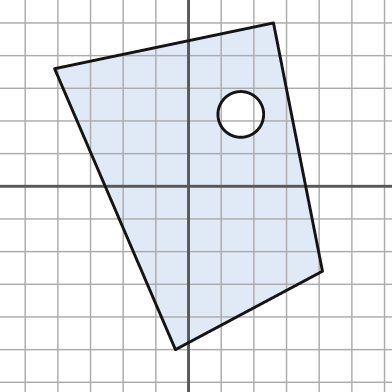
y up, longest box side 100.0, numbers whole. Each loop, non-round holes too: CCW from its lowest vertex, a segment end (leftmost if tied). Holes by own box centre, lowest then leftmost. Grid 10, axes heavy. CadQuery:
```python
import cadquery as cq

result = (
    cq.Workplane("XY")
    .moveTo(-4.0, -50.0)
    .lineTo(41.0, -26.0)
    .lineTo(26.0, 50.0)
    .lineTo(-41.0, 36.0)
    .close()
    .moveTo(16.0, 22.0)
    .circle(7.0)
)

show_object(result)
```